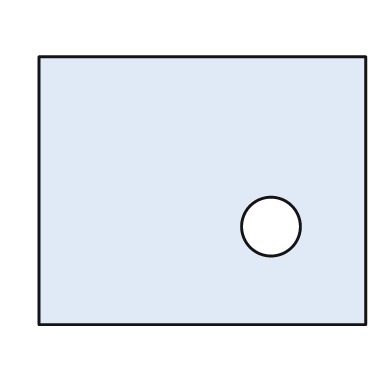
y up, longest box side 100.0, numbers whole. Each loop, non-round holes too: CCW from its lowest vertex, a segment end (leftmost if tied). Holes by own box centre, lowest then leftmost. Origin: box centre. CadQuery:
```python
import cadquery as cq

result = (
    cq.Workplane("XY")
    .moveTo(-50.0, -41.0)
    .lineTo(50.0, -41.0)
    .lineTo(50.0, 41.0)
    .lineTo(-50.0, 41.0)
    .close()
    .moveTo(21.0, -11.0)
    .circle(9.0)
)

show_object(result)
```